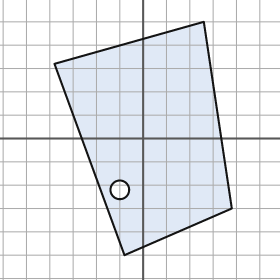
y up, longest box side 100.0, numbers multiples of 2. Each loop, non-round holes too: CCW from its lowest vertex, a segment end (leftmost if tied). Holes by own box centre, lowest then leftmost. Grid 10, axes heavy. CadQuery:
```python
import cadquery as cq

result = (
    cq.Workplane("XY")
    .moveTo(-8.0, -50.0)
    .lineTo(38.0, -30.0)
    .lineTo(26.0, 50.0)
    .lineTo(-38.0, 32.0)
    .close()
    .moveTo(-10.0, -22.0)
    .circle(4.0)
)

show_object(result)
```